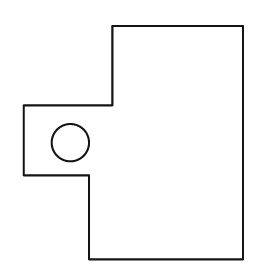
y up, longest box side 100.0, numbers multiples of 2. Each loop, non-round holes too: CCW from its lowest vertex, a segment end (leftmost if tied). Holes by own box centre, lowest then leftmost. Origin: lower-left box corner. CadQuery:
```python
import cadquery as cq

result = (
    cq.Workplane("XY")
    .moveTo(28.0, 0.0)
    .lineTo(94.0, 0.0)
    .lineTo(94.0, 100.0)
    .lineTo(38.0, 100.0)
    .lineTo(38.0, 66.0)
    .lineTo(0.0, 66.0)
    .lineTo(0.0, 36.0)
    .lineTo(28.0, 36.0)
    .close()
    .moveTo(20.0, 50.0)
    .circle(8.0)
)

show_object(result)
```